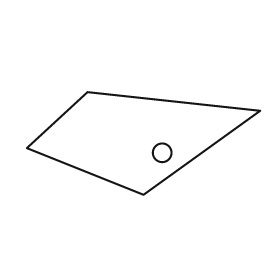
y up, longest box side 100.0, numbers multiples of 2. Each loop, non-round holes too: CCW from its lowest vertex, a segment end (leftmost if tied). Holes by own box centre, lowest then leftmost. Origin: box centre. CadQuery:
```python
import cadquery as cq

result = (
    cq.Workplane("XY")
    .moveTo(0.0, -22.0)
    .lineTo(50.0, 14.0)
    .lineTo(-24.0, 22.0)
    .lineTo(-50.0, -2.0)
    .close()
    .moveTo(8.0, -4.0)
    .circle(4.0)
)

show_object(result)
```